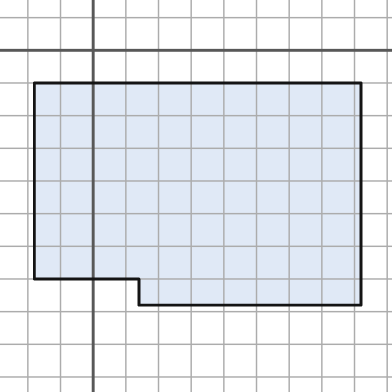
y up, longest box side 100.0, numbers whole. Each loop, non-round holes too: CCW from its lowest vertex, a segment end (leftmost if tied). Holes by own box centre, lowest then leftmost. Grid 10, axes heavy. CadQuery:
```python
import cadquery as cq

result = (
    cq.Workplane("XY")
    .moveTo(14.0, -78.0)
    .lineTo(82.0, -78.0)
    .lineTo(82.0, -10.0)
    .lineTo(-18.0, -10.0)
    .lineTo(-18.0, -70.0)
    .lineTo(14.0, -70.0)
    .close()
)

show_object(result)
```